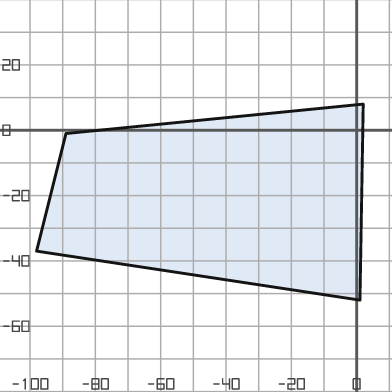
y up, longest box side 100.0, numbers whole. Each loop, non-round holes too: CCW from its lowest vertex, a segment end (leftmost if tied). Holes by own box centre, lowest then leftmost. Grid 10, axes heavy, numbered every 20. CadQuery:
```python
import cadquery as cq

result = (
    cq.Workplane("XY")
    .moveTo(1.0, -52.0)
    .lineTo(2.0, 8.0)
    .lineTo(-89.0, -1.0)
    .lineTo(-98.0, -37.0)
    .close()
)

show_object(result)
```